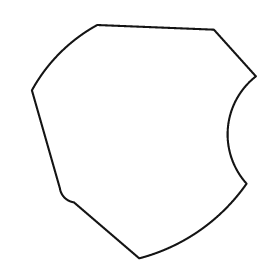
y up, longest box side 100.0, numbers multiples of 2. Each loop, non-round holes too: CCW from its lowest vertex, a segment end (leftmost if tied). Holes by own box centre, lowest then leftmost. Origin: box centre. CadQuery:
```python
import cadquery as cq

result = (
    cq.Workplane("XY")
    .moveTo(-2.0, -50.0)
    .threePointArc((24.0, -38.0), (44.0, -18.0))
    .threePointArc((36.0, 6.0), (48.0, 28.0))
    .lineTo(30.0, 48.0)
    .lineTo(-20.0, 50.0)
    .threePointArc((-36.0, 38.0), (-48.0, 22.0))
    .lineTo(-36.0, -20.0)
    .threePointArc((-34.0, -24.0), (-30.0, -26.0))
    .close()
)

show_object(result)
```